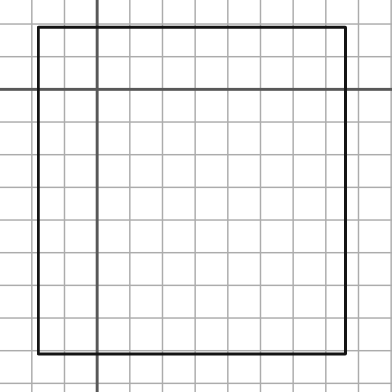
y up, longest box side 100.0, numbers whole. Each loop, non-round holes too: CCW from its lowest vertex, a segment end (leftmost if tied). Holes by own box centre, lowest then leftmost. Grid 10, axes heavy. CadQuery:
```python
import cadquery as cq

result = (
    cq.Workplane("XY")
    .moveTo(-18.0, -81.0)
    .lineTo(76.0, -81.0)
    .lineTo(76.0, 19.0)
    .lineTo(-18.0, 19.0)
    .close()
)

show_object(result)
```